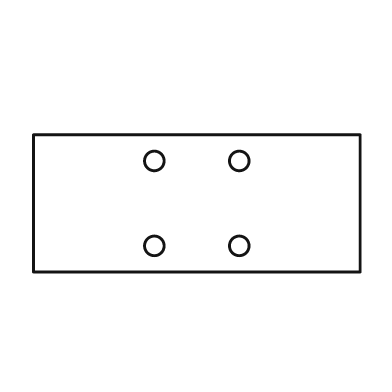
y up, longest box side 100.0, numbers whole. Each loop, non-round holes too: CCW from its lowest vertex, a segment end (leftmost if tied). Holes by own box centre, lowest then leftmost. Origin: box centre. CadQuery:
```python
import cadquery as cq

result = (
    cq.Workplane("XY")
    .moveTo(-50.0, -21.0)
    .lineTo(50.0, -21.0)
    .lineTo(50.0, 21.0)
    .lineTo(-50.0, 21.0)
    .close()
    .moveTo(-13.0, -13.0)
    .circle(3.0)
    .moveTo(13.0, -13.0)
    .circle(3.0)
    .moveTo(-13.0, 13.0)
    .circle(3.0)
    .moveTo(13.0, 13.0)
    .circle(3.0)
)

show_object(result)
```